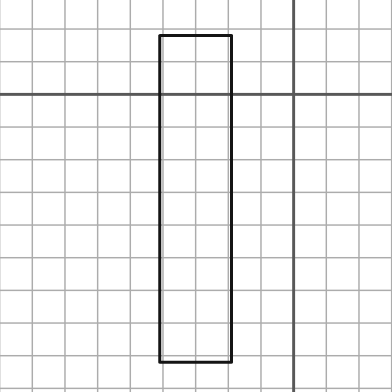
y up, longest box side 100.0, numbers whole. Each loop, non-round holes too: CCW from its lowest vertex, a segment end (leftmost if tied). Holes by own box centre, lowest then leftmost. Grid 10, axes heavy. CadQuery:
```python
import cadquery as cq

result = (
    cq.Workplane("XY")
    .moveTo(-41.0, -82.0)
    .lineTo(-19.0, -82.0)
    .lineTo(-19.0, 18.0)
    .lineTo(-41.0, 18.0)
    .close()
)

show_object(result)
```